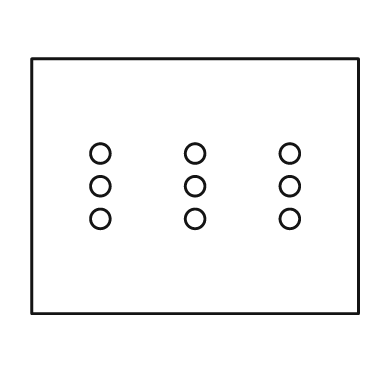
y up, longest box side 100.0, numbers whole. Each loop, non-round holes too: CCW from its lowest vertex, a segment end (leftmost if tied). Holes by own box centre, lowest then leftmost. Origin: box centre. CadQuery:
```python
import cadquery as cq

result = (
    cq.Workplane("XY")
    .moveTo(-50.0, -39.0)
    .lineTo(50.0, -39.0)
    .lineTo(50.0, 39.0)
    .lineTo(-50.0, 39.0)
    .close()
    .moveTo(-29.0, -10.0)
    .circle(3.0)
    .moveTo(0.0, -10.0)
    .circle(3.0)
    .moveTo(29.0, -10.0)
    .circle(3.0)
    .moveTo(-29.0, 0.0)
    .circle(3.0)
    .moveTo(0.0, 0.0)
    .circle(3.0)
    .moveTo(29.0, 0.0)
    .circle(3.0)
    .moveTo(-29.0, 10.0)
    .circle(3.0)
    .moveTo(0.0, 10.0)
    .circle(3.0)
    .moveTo(29.0, 10.0)
    .circle(3.0)
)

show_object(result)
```